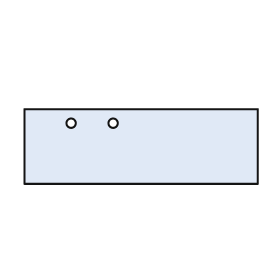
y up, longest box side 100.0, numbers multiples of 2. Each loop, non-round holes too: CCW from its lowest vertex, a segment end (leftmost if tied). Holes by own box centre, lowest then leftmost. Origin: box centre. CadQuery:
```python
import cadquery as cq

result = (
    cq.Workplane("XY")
    .moveTo(-50.0, -16.0)
    .lineTo(50.0, -16.0)
    .lineTo(50.0, 16.0)
    .lineTo(-50.0, 16.0)
    .close()
    .moveTo(-30.0, 10.0)
    .circle(2.0)
    .moveTo(-12.0, 10.0)
    .circle(2.0)
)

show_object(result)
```